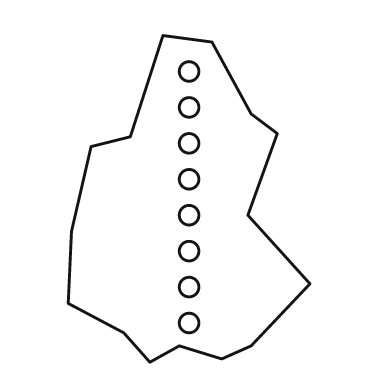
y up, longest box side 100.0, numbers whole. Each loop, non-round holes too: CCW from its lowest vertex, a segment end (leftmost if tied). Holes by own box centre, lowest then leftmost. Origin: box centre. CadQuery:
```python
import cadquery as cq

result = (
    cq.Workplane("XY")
    .moveTo(-12.0, -50.0)
    .lineTo(-3.0, -45.0)
    .lineTo(10.0, -49.0)
    .lineTo(19.0, -45.0)
    .lineTo(37.0, -26.0)
    .lineTo(18.0, -5.0)
    .lineTo(27.0, 20.0)
    .lineTo(19.0, 26.0)
    .lineTo(7.0, 48.0)
    .lineTo(-8.0, 50.0)
    .lineTo(-18.0, 19.0)
    .lineTo(-30.0, 16.0)
    .lineTo(-36.0, -10.0)
    .lineTo(-37.0, -32.0)
    .lineTo(-20.0, -41.0)
    .close()
    .moveTo(0.0, -38.0)
    .circle(3.0)
    .moveTo(0.0, -27.0)
    .circle(3.0)
    .moveTo(0.0, -16.0)
    .circle(3.0)
    .moveTo(0.0, -5.0)
    .circle(3.0)
    .moveTo(0.0, 6.0)
    .circle(3.0)
    .moveTo(0.0, 17.0)
    .circle(3.0)
    .moveTo(0.0, 28.0)
    .circle(3.0)
    .moveTo(0.0, 39.0)
    .circle(3.0)
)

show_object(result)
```